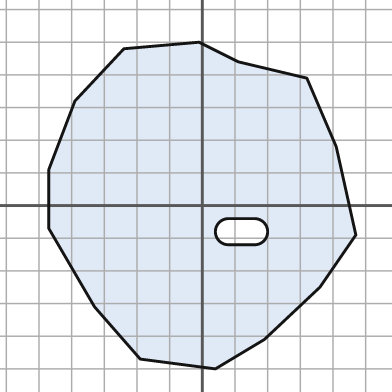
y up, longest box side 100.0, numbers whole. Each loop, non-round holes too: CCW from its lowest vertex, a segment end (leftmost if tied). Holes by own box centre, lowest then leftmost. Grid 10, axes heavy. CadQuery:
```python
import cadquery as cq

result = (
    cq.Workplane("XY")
    .moveTo(4.0, -50.0)
    .lineTo(19.0, -41.0)
    .lineTo(36.0, -25.0)
    .lineTo(47.0, -9.0)
    .lineTo(41.0, 18.0)
    .lineTo(32.0, 39.0)
    .lineTo(11.0, 44.0)
    .lineTo(-1.0, 50.0)
    .lineTo(-24.0, 48.0)
    .lineTo(-39.0, 32.0)
    .lineTo(-47.0, 11.0)
    .lineTo(-47.0, -7.0)
    .lineTo(-33.0, -31.0)
    .lineTo(-19.0, -47.0)
    .close()
    .moveTo(8.0, -12.0)
    .lineTo(16.0, -12.0)
    .threePointArc((20.0, -8.0), (16.0, -4.0))
    .lineTo(8.0, -4.0)
    .threePointArc((4.0, -8.0), (8.0, -12.0))
    .close()
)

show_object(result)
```